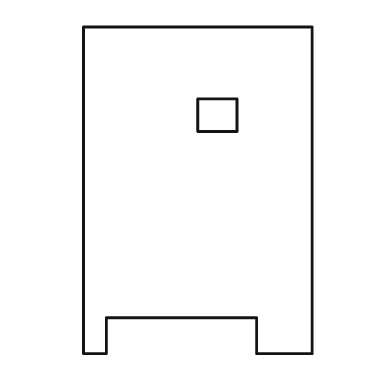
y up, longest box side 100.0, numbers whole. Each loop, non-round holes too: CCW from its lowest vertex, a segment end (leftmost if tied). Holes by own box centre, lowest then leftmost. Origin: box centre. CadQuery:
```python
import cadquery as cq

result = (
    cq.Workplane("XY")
    .moveTo(-35.0, -50.0)
    .lineTo(-28.0, -50.0)
    .lineTo(-28.0, -39.0)
    .lineTo(18.0, -39.0)
    .lineTo(18.0, -50.0)
    .lineTo(35.0, -50.0)
    .lineTo(35.0, 50.0)
    .lineTo(-35.0, 50.0)
    .close()
    .moveTo(0.0, 18.0)
    .lineTo(12.0, 18.0)
    .lineTo(12.0, 28.0)
    .lineTo(0.0, 28.0)
    .close()
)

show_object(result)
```